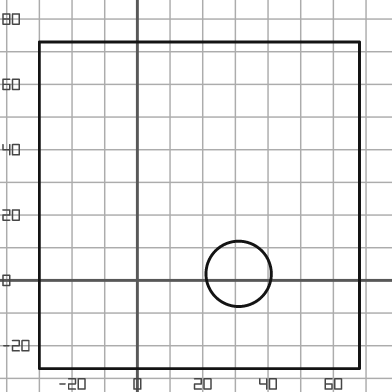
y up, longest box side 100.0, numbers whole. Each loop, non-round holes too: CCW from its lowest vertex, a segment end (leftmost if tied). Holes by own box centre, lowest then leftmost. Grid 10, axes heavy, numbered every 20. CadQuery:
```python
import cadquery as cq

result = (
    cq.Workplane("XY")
    .moveTo(-30.0, -27.0)
    .lineTo(68.0, -27.0)
    .lineTo(68.0, 73.0)
    .lineTo(-30.0, 73.0)
    .close()
    .moveTo(31.0, 2.0)
    .circle(10.0)
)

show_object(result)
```